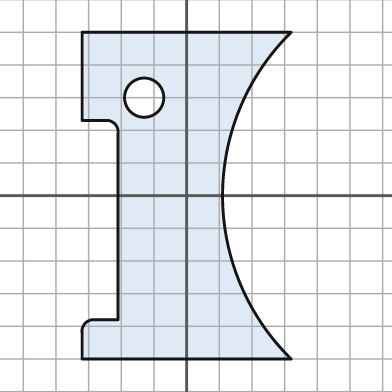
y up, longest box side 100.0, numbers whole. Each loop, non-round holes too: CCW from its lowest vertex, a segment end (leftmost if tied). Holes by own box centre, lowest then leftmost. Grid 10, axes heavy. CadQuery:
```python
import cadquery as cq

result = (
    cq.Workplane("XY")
    .moveTo(-32.0, -50.0)
    .lineTo(32.0, -50.0)
    .threePointArc((11.0, 0.0), (32.0, 50.0))
    .lineTo(-32.0, 50.0)
    .lineTo(-32.0, 23.0)
    .lineTo(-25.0, 23.0)
    .threePointArc((-22.0, 22.0), (-21.0, 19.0))
    .lineTo(-21.0, -38.0)
    .lineTo(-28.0, -38.0)
    .threePointArc((-31.0, -39.0), (-32.0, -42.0))
    .close()
    .moveTo(-13.0, 30.0)
    .circle(6.0)
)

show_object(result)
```